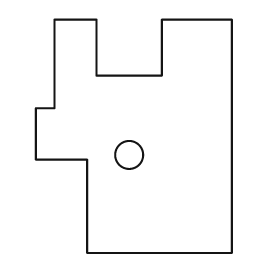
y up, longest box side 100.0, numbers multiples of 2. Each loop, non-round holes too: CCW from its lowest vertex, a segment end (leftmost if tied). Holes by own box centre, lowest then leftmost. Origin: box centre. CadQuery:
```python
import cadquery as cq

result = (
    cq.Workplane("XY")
    .moveTo(-20.0, -50.0)
    .lineTo(42.0, -50.0)
    .lineTo(42.0, 50.0)
    .lineTo(12.0, 50.0)
    .lineTo(12.0, 26.0)
    .lineTo(-16.0, 26.0)
    .lineTo(-16.0, 50.0)
    .lineTo(-34.0, 50.0)
    .lineTo(-34.0, 12.0)
    .lineTo(-42.0, 12.0)
    .lineTo(-42.0, -10.0)
    .lineTo(-20.0, -10.0)
    .close()
    .moveTo(-2.0, -8.0)
    .circle(6.0)
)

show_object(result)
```